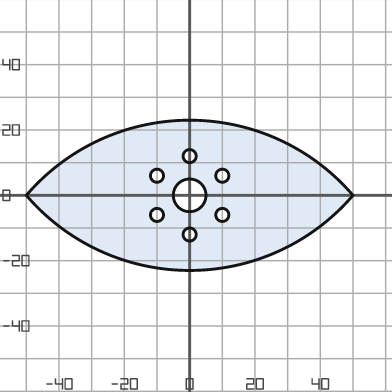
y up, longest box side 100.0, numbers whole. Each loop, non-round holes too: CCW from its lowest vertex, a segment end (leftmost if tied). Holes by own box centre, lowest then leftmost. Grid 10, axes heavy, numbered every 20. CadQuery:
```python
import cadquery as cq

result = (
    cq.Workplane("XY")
    .moveTo(-50.0, 0.0)
    .threePointArc((0.0, -23.0), (50.0, 0.0))
    .threePointArc((0.0, 23.0), (-50.0, 0.0))
    .close()
    .moveTo(0.0, -12.0)
    .circle(2.0)
    .moveTo(-10.0, -6.0)
    .circle(2.0)
    .moveTo(10.0, -6.0)
    .circle(2.0)
    .moveTo(0.0, 0.0)
    .circle(5.0)
    .moveTo(-10.0, 6.0)
    .circle(2.0)
    .moveTo(10.0, 6.0)
    .circle(2.0)
    .moveTo(0.0, 12.0)
    .circle(2.0)
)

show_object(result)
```